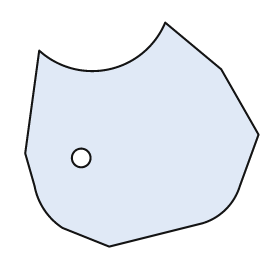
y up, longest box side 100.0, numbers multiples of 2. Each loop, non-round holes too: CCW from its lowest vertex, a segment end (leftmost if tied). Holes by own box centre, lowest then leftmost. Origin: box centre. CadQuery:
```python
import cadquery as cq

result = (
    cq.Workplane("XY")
    .moveTo(-14.0, -48.0)
    .lineTo(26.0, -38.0)
    .threePointArc((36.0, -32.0), (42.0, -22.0))
    .lineTo(50.0, 0.0)
    .lineTo(34.0, 28.0)
    .lineTo(10.0, 48.0)
    .threePointArc((-14.0, 28.0), (-44.0, 36.0))
    .lineTo(-50.0, -8.0)
    .lineTo(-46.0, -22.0)
    .threePointArc((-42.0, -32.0), (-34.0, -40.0))
    .close()
    .moveTo(-26.0, -10.0)
    .circle(4.0)
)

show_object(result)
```